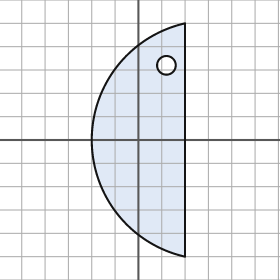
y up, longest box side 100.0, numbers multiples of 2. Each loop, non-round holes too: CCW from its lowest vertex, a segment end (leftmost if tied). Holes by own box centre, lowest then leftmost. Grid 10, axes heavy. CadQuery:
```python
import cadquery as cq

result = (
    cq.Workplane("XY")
    .moveTo(20.0, -50.0)
    .lineTo(20.0, 50.0)
    .threePointArc((-20.0, 0.0), (20.0, -50.0))
    .close()
    .moveTo(12.0, 32.0)
    .circle(4.0)
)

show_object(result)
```